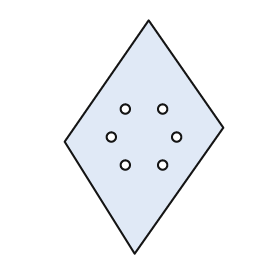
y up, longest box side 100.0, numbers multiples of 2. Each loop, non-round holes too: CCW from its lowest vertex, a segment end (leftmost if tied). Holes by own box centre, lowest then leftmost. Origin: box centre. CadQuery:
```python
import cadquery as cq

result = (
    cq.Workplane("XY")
    .moveTo(-4.0, -50.0)
    .lineTo(34.0, 4.0)
    .lineTo(2.0, 50.0)
    .lineTo(-34.0, -2.0)
    .close()
    .moveTo(-8.0, -12.0)
    .circle(2.0)
    .moveTo(8.0, -12.0)
    .circle(2.0)
    .moveTo(-14.0, 0.0)
    .circle(2.0)
    .moveTo(14.0, 0.0)
    .circle(2.0)
    .moveTo(-8.0, 12.0)
    .circle(2.0)
    .moveTo(8.0, 12.0)
    .circle(2.0)
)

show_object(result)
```